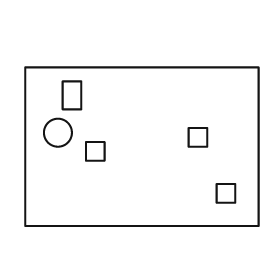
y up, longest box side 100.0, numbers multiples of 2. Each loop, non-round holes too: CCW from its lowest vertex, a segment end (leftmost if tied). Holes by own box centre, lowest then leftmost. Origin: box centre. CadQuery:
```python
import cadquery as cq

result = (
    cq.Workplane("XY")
    .moveTo(-50.0, -34.0)
    .lineTo(50.0, -34.0)
    .lineTo(50.0, 34.0)
    .lineTo(-50.0, 34.0)
    .close()
    .moveTo(32.0, -24.0)
    .lineTo(40.0, -24.0)
    .lineTo(40.0, -16.0)
    .lineTo(32.0, -16.0)
    .close()
    .moveTo(-24.0, -6.0)
    .lineTo(-16.0, -6.0)
    .lineTo(-16.0, 2.0)
    .lineTo(-24.0, 2.0)
    .close()
    .moveTo(20.0, 0.0)
    .lineTo(28.0, 0.0)
    .lineTo(28.0, 8.0)
    .lineTo(20.0, 8.0)
    .close()
    .moveTo(-36.0, 6.0)
    .circle(6.0)
    .moveTo(-34.0, 16.0)
    .lineTo(-26.0, 16.0)
    .lineTo(-26.0, 28.0)
    .lineTo(-34.0, 28.0)
    .close()
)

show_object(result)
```